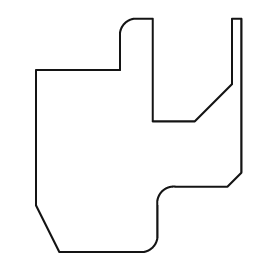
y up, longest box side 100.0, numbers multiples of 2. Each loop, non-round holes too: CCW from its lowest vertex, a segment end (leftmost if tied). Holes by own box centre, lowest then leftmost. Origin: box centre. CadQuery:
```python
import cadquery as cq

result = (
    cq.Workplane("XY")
    .moveTo(-34.0, -50.0)
    .lineTo(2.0, -50.0)
    .threePointArc((6.0, -48.0), (8.0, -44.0))
    .lineTo(8.0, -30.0)
    .threePointArc((10.0, -24.0), (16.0, -22.0))
    .lineTo(38.0, -22.0)
    .lineTo(44.0, -16.0)
    .lineTo(44.0, 50.0)
    .lineTo(40.0, 50.0)
    .lineTo(40.0, 22.0)
    .lineTo(24.0, 6.0)
    .lineTo(6.0, 6.0)
    .lineTo(6.0, 50.0)
    .lineTo(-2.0, 50.0)
    .threePointArc((-6.0, 48.0), (-8.0, 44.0))
    .lineTo(-8.0, 28.0)
    .lineTo(-44.0, 28.0)
    .lineTo(-44.0, -30.0)
    .close()
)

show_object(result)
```